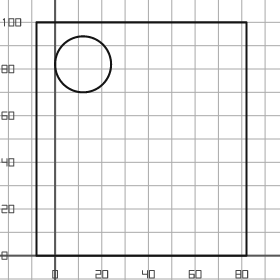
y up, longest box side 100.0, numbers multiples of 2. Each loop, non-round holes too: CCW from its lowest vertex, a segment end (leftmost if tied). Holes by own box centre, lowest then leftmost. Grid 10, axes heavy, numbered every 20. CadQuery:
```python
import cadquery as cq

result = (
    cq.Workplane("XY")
    .moveTo(-8.0, 0.0)
    .lineTo(82.0, 0.0)
    .lineTo(82.0, 100.0)
    .lineTo(-8.0, 100.0)
    .close()
    .moveTo(12.0, 82.0)
    .circle(12.0)
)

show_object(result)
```